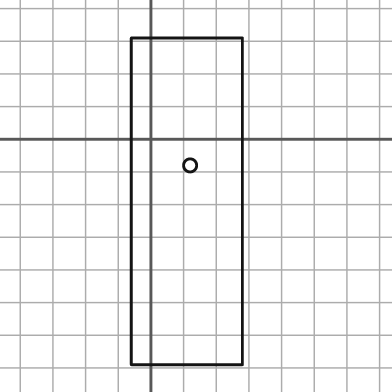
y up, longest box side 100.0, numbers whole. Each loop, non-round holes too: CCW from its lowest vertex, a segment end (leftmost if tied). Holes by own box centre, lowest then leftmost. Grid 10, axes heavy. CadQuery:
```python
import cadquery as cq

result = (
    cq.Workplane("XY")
    .moveTo(-6.0, -69.0)
    .lineTo(28.0, -69.0)
    .lineTo(28.0, 31.0)
    .lineTo(-6.0, 31.0)
    .close()
    .moveTo(12.0, -8.0)
    .circle(2.0)
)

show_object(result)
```